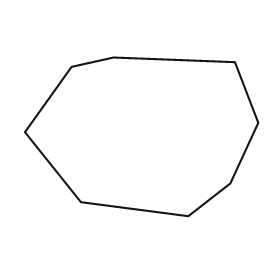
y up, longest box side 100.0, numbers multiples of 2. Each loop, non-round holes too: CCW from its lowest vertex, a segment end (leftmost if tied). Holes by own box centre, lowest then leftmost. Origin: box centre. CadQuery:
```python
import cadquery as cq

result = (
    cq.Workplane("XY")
    .moveTo(20.0, -34.0)
    .lineTo(38.0, -20.0)
    .lineTo(50.0, 6.0)
    .lineTo(40.0, 32.0)
    .lineTo(-12.0, 34.0)
    .lineTo(-30.0, 30.0)
    .lineTo(-50.0, 2.0)
    .lineTo(-26.0, -28.0)
    .close()
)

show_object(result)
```